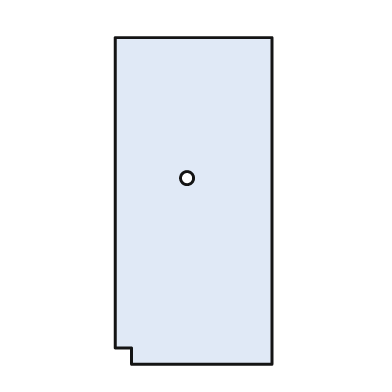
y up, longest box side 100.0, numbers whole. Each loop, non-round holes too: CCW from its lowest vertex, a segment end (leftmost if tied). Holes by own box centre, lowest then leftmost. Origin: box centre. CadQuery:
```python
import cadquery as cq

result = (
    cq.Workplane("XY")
    .moveTo(-19.0, -50.0)
    .lineTo(24.0, -50.0)
    .lineTo(24.0, 50.0)
    .lineTo(-24.0, 50.0)
    .lineTo(-24.0, -45.0)
    .lineTo(-19.0, -45.0)
    .close()
    .moveTo(-2.0, 7.0)
    .circle(2.0)
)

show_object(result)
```